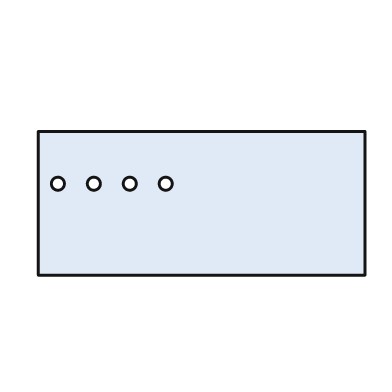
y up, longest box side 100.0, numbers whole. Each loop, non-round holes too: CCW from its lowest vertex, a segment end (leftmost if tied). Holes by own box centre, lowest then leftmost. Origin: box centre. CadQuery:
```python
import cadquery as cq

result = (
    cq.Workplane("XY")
    .moveTo(-50.0, -22.0)
    .lineTo(50.0, -22.0)
    .lineTo(50.0, 22.0)
    .lineTo(-50.0, 22.0)
    .close()
    .moveTo(-44.0, 6.0)
    .circle(2.0)
    .moveTo(-33.0, 6.0)
    .circle(2.0)
    .moveTo(-22.0, 6.0)
    .circle(2.0)
    .moveTo(-11.0, 6.0)
    .circle(2.0)
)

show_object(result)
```